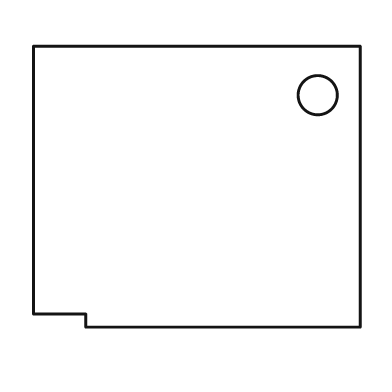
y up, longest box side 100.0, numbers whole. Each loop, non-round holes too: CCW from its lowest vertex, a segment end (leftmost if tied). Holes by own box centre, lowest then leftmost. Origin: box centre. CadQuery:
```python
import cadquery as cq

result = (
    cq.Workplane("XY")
    .moveTo(-34.0, -43.0)
    .lineTo(50.0, -43.0)
    .lineTo(50.0, 43.0)
    .lineTo(-50.0, 43.0)
    .lineTo(-50.0, -39.0)
    .lineTo(-34.0, -39.0)
    .close()
    .moveTo(37.0, 28.0)
    .circle(6.0)
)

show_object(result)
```